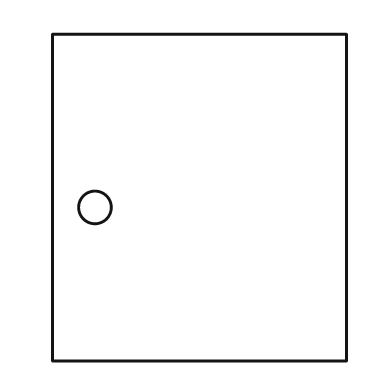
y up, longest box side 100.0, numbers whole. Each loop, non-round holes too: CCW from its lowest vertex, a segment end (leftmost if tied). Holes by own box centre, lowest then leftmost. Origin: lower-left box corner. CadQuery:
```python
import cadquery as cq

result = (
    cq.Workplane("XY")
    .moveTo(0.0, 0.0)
    .lineTo(90.0, 0.0)
    .lineTo(90.0, 100.0)
    .lineTo(0.0, 100.0)
    .close()
    .moveTo(13.0, 47.0)
    .circle(5.0)
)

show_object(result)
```